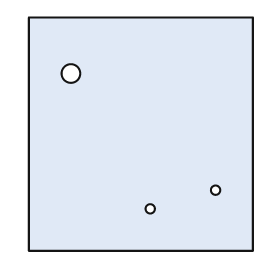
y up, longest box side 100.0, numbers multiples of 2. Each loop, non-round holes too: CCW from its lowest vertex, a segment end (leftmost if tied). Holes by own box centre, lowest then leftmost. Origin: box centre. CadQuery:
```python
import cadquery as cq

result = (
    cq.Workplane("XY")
    .moveTo(-48.0, -50.0)
    .lineTo(48.0, -50.0)
    .lineTo(48.0, 50.0)
    .lineTo(-48.0, 50.0)
    .close()
    .moveTo(4.0, -32.0)
    .circle(2.0)
    .moveTo(32.0, -24.0)
    .circle(2.0)
    .moveTo(-30.0, 26.0)
    .circle(4.0)
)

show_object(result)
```